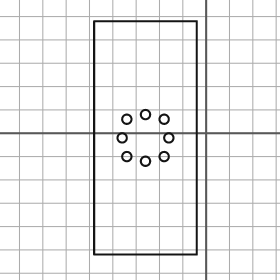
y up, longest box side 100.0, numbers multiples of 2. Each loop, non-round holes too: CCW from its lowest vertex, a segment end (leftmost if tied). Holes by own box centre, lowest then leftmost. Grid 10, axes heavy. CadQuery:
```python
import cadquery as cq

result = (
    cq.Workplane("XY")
    .moveTo(-48.0, -52.0)
    .lineTo(-4.0, -52.0)
    .lineTo(-4.0, 48.0)
    .lineTo(-48.0, 48.0)
    .close()
    .moveTo(-26.0, -12.0)
    .circle(2.0)
    .moveTo(-34.0, -10.0)
    .circle(2.0)
    .moveTo(-18.0, -10.0)
    .circle(2.0)
    .moveTo(-36.0, -2.0)
    .circle(2.0)
    .moveTo(-16.0, -2.0)
    .circle(2.0)
    .moveTo(-34.0, 6.0)
    .circle(2.0)
    .moveTo(-18.0, 6.0)
    .circle(2.0)
    .moveTo(-26.0, 8.0)
    .circle(2.0)
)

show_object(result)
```